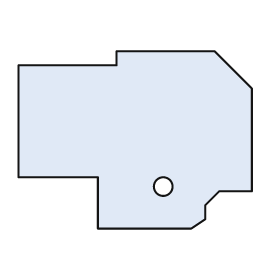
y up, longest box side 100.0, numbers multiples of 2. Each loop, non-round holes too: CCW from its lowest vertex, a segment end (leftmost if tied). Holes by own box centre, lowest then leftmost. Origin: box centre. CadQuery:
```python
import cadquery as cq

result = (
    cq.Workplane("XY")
    .moveTo(-16.0, -38.0)
    .lineTo(24.0, -38.0)
    .lineTo(30.0, -34.0)
    .lineTo(30.0, -28.0)
    .lineTo(36.0, -22.0)
    .lineTo(50.0, -22.0)
    .lineTo(50.0, 22.0)
    .lineTo(34.0, 38.0)
    .lineTo(-8.0, 38.0)
    .lineTo(-8.0, 32.0)
    .lineTo(-50.0, 32.0)
    .lineTo(-50.0, -16.0)
    .lineTo(-16.0, -16.0)
    .close()
    .moveTo(12.0, -20.0)
    .circle(4.0)
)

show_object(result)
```